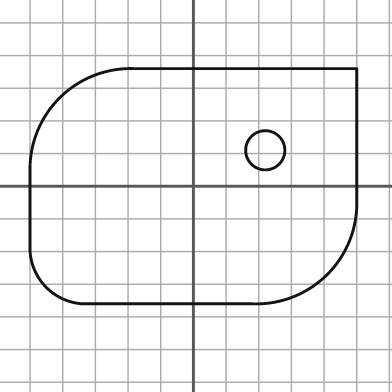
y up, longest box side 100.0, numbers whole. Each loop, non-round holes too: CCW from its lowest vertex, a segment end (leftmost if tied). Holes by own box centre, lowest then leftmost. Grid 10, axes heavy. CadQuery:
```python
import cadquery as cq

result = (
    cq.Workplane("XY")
    .moveTo(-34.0, -36.0)
    .lineTo(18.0, -36.0)
    .threePointArc((41.0, -27.0), (50.0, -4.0))
    .lineTo(50.0, 36.0)
    .lineTo(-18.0, 36.0)
    .threePointArc((-41.0, 27.0), (-50.0, 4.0))
    .lineTo(-50.0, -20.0)
    .threePointArc((-45.0, -31.0), (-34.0, -36.0))
    .close()
    .moveTo(22.0, 11.0)
    .circle(6.0)
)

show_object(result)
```